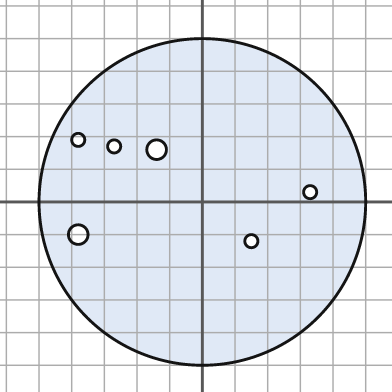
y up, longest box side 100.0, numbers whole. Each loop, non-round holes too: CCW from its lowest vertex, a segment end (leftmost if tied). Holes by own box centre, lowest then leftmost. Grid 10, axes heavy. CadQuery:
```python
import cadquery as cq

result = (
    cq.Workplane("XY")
    .moveTo(0.0, 0.0)
    .circle(50.0)
    .moveTo(15.0, -12.0)
    .circle(2.0)
    .moveTo(-38.0, -10.0)
    .circle(3.0)
    .moveTo(33.0, 3.0)
    .circle(2.0)
    .moveTo(-14.0, 16.0)
    .circle(3.0)
    .moveTo(-27.0, 17.0)
    .circle(2.0)
    .moveTo(-38.0, 19.0)
    .circle(2.0)
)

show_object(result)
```